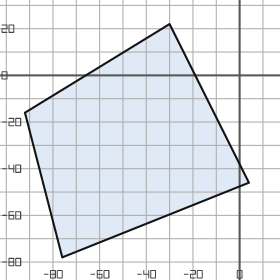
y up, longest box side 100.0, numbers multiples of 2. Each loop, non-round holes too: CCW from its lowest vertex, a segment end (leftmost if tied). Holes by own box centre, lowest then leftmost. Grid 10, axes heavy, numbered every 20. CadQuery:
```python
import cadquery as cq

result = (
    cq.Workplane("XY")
    .moveTo(-76.0, -78.0)
    .lineTo(4.0, -46.0)
    .lineTo(-30.0, 22.0)
    .lineTo(-92.0, -16.0)
    .close()
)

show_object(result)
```